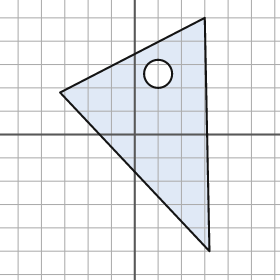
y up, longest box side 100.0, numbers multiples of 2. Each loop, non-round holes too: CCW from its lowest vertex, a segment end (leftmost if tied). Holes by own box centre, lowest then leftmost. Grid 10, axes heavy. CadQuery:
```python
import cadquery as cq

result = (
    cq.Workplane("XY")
    .moveTo(32.0, -50.0)
    .lineTo(30.0, 50.0)
    .lineTo(-32.0, 18.0)
    .close()
    .moveTo(10.0, 26.0)
    .circle(6.0)
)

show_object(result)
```